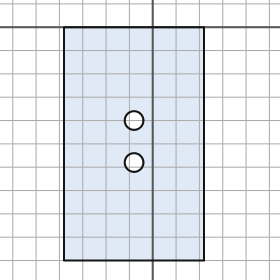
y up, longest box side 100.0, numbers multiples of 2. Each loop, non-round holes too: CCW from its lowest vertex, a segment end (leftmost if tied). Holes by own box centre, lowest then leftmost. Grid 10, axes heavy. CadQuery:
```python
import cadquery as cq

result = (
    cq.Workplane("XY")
    .moveTo(-38.0, -100.0)
    .lineTo(22.0, -100.0)
    .lineTo(22.0, 0.0)
    .lineTo(-38.0, 0.0)
    .close()
    .moveTo(-8.0, -58.0)
    .circle(4.0)
    .moveTo(-8.0, -40.0)
    .circle(4.0)
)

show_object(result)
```